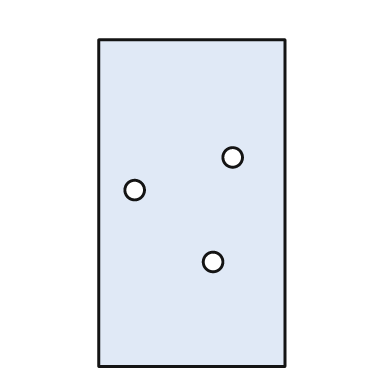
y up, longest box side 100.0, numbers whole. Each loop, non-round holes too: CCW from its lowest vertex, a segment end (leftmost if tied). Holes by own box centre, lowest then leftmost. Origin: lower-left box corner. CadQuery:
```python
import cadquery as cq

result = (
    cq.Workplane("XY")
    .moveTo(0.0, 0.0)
    .lineTo(57.0, 0.0)
    .lineTo(57.0, 100.0)
    .lineTo(0.0, 100.0)
    .close()
    .moveTo(35.0, 32.0)
    .circle(3.0)
    .moveTo(11.0, 54.0)
    .circle(3.0)
    .moveTo(41.0, 64.0)
    .circle(3.0)
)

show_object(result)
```